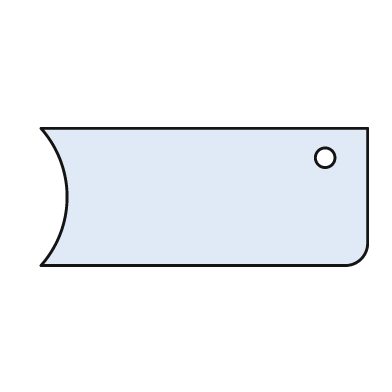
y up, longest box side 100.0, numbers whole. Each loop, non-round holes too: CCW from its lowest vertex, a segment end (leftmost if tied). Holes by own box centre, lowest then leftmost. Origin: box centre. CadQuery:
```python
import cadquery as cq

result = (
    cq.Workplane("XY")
    .moveTo(-50.0, -21.0)
    .lineTo(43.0, -21.0)
    .threePointArc((48.0, -19.0), (50.0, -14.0))
    .lineTo(50.0, 21.0)
    .lineTo(-50.0, 21.0)
    .threePointArc((-42.0, 0.0), (-50.0, -21.0))
    .close()
    .moveTo(37.0, 12.0)
    .circle(3.0)
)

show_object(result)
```